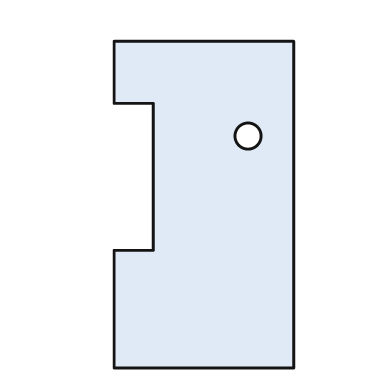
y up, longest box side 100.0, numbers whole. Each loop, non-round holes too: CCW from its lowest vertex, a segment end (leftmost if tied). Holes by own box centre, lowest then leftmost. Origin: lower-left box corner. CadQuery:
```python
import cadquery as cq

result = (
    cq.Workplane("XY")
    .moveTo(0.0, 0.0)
    .lineTo(55.0, 0.0)
    .lineTo(55.0, 100.0)
    .lineTo(0.0, 100.0)
    .lineTo(0.0, 81.0)
    .lineTo(12.0, 81.0)
    .lineTo(12.0, 36.0)
    .lineTo(0.0, 36.0)
    .close()
    .moveTo(41.0, 71.0)
    .circle(4.0)
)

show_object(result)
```